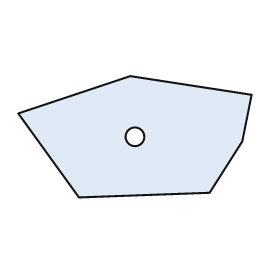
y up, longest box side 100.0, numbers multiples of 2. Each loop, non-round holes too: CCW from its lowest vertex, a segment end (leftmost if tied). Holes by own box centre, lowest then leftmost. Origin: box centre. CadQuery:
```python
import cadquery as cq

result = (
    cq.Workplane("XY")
    .moveTo(-24.0, -26.0)
    .lineTo(32.0, -24.0)
    .lineTo(46.0, -2.0)
    .lineTo(50.0, 18.0)
    .lineTo(-2.0, 26.0)
    .lineTo(-50.0, 10.0)
    .close()
    .moveTo(0.0, 0.0)
    .circle(4.0)
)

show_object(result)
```